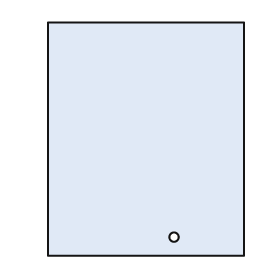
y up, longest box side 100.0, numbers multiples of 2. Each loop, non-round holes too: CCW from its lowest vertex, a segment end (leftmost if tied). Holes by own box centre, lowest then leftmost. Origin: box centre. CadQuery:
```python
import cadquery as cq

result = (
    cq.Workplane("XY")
    .moveTo(-42.0, -50.0)
    .lineTo(42.0, -50.0)
    .lineTo(42.0, 50.0)
    .lineTo(-42.0, 50.0)
    .close()
    .moveTo(12.0, -42.0)
    .circle(2.0)
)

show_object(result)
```